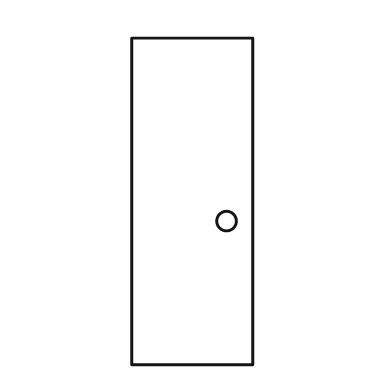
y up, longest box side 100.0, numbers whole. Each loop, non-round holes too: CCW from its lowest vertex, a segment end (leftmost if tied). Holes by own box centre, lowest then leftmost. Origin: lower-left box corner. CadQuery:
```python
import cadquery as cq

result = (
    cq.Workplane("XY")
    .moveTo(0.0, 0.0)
    .lineTo(37.0, 0.0)
    .lineTo(37.0, 100.0)
    .lineTo(0.0, 100.0)
    .close()
    .moveTo(29.0, 44.0)
    .circle(3.0)
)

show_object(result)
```